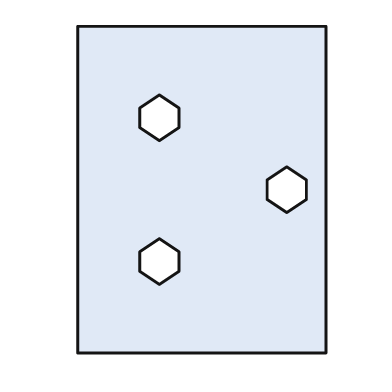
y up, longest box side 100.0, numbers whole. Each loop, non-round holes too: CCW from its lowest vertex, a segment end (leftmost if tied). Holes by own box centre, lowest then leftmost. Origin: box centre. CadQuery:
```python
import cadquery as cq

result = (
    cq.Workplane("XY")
    .moveTo(-38.0, -50.0)
    .lineTo(38.0, -50.0)
    .lineTo(38.0, 50.0)
    .lineTo(-38.0, 50.0)
    .close()
    .moveTo(-13.0, -29.0)
    .lineTo(-7.0, -25.0)
    .lineTo(-7.0, -19.0)
    .lineTo(-13.0, -15.0)
    .lineTo(-19.0, -19.0)
    .lineTo(-19.0, -25.0)
    .close()
    .moveTo(26.0, -7.0)
    .lineTo(32.0, -3.0)
    .lineTo(32.0, 3.0)
    .lineTo(26.0, 7.0)
    .lineTo(20.0, 3.0)
    .lineTo(20.0, -3.0)
    .close()
    .moveTo(-13.0, 15.0)
    .lineTo(-7.0, 19.0)
    .lineTo(-7.0, 25.0)
    .lineTo(-13.0, 29.0)
    .lineTo(-19.0, 25.0)
    .lineTo(-19.0, 19.0)
    .close()
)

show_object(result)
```